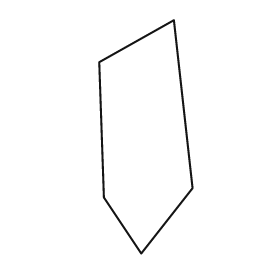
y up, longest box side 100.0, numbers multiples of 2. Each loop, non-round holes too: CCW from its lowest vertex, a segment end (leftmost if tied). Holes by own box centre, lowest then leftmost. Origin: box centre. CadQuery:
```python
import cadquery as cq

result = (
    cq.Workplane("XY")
    .moveTo(-2.0, -50.0)
    .lineTo(20.0, -22.0)
    .lineTo(12.0, 50.0)
    .lineTo(-20.0, 32.0)
    .lineTo(-18.0, -26.0)
    .close()
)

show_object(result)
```